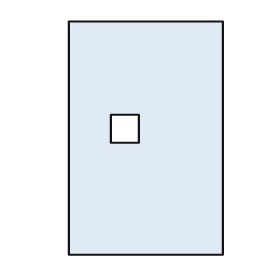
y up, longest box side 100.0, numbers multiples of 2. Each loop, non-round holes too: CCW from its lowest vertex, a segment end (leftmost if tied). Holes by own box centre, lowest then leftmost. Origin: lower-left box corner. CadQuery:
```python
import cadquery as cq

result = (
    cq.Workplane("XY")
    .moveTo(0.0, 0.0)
    .lineTo(66.0, 0.0)
    .lineTo(66.0, 100.0)
    .lineTo(0.0, 100.0)
    .close()
    .moveTo(18.0, 48.0)
    .lineTo(30.0, 48.0)
    .lineTo(30.0, 60.0)
    .lineTo(18.0, 60.0)
    .close()
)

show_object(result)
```